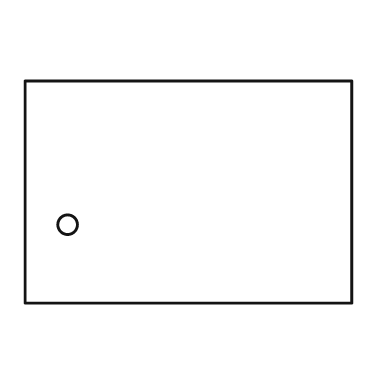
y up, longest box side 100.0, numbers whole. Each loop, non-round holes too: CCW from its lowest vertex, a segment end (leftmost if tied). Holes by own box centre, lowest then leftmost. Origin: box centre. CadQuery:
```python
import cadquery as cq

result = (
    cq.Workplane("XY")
    .moveTo(-50.0, -34.0)
    .lineTo(50.0, -34.0)
    .lineTo(50.0, 34.0)
    .lineTo(-50.0, 34.0)
    .close()
    .moveTo(-37.0, -10.0)
    .circle(3.0)
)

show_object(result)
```